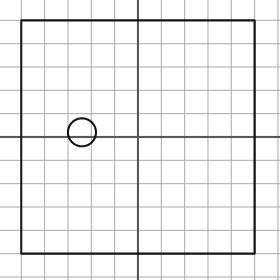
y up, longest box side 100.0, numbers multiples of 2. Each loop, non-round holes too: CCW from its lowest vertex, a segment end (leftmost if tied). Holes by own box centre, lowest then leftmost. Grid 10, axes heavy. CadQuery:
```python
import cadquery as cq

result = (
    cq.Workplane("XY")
    .moveTo(-50.0, -50.0)
    .lineTo(50.0, -50.0)
    .lineTo(50.0, 50.0)
    .lineTo(-50.0, 50.0)
    .close()
    .moveTo(-24.0, 2.0)
    .circle(6.0)
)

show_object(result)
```